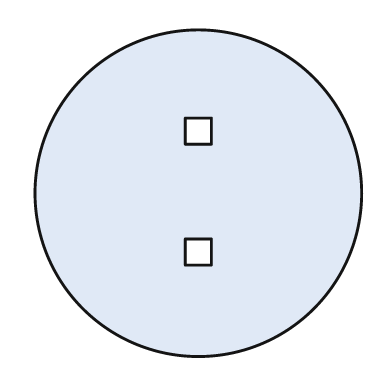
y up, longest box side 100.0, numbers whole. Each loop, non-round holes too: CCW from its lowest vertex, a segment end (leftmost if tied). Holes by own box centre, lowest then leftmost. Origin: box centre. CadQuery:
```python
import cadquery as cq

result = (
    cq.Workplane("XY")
    .moveTo(0.0, 0.0)
    .circle(50.0)
    .moveTo(-4.0, -22.0)
    .lineTo(4.0, -22.0)
    .lineTo(4.0, -14.0)
    .lineTo(-4.0, -14.0)
    .close()
    .moveTo(-4.0, 15.0)
    .lineTo(4.0, 15.0)
    .lineTo(4.0, 23.0)
    .lineTo(-4.0, 23.0)
    .close()
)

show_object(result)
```